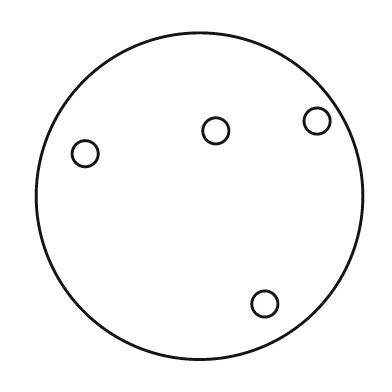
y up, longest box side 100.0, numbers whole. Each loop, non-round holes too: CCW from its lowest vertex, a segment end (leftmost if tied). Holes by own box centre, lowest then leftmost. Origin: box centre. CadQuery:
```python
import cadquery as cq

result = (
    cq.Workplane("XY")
    .moveTo(0.0, 0.0)
    .circle(50.0)
    .moveTo(20.0, -33.0)
    .circle(4.0)
    .moveTo(-35.0, 13.0)
    .circle(4.0)
    .moveTo(5.0, 20.0)
    .circle(4.0)
    .moveTo(36.0, 23.0)
    .circle(4.0)
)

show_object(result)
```